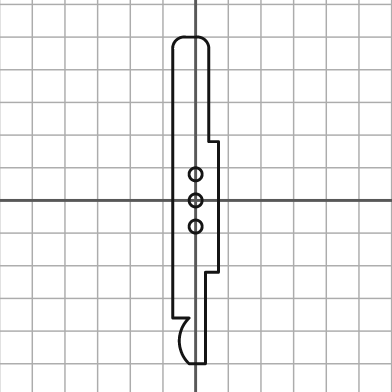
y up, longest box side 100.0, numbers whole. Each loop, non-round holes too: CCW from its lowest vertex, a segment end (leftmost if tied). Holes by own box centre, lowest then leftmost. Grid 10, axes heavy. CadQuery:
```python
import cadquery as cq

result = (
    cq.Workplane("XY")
    .moveTo(-2.0, -50.0)
    .lineTo(3.0, -50.0)
    .lineTo(3.0, -22.0)
    .lineTo(7.0, -22.0)
    .lineTo(7.0, 18.0)
    .lineTo(4.0, 18.0)
    .lineTo(4.0, 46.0)
    .threePointArc((3.0, 49.0), (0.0, 50.0))
    .lineTo(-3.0, 50.0)
    .threePointArc((-6.0, 49.0), (-7.0, 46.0))
    .lineTo(-7.0, -36.0)
    .lineTo(-2.0, -36.0)
    .threePointArc((-5.0, -43.0), (-2.0, -50.0))
    .close()
    .moveTo(0.0, -8.0)
    .circle(2.0)
    .moveTo(0.0, 0.0)
    .circle(2.0)
    .moveTo(0.0, 8.0)
    .circle(2.0)
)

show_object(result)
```